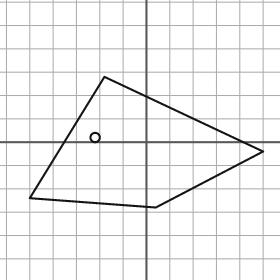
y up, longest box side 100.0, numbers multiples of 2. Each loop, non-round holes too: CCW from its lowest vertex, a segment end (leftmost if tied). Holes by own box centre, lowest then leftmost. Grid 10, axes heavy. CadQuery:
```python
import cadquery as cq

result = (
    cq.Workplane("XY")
    .moveTo(4.0, -28.0)
    .lineTo(50.0, -4.0)
    .lineTo(-18.0, 28.0)
    .lineTo(-50.0, -24.0)
    .close()
    .moveTo(-22.0, 2.0)
    .circle(2.0)
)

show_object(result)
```